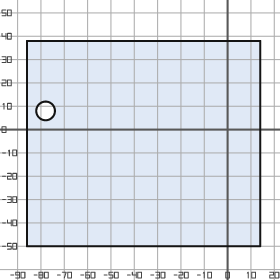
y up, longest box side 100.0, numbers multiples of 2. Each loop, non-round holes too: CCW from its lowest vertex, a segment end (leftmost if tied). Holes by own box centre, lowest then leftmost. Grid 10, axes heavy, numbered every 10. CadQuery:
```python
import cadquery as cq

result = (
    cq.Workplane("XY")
    .moveTo(-86.0, -50.0)
    .lineTo(14.0, -50.0)
    .lineTo(14.0, 38.0)
    .lineTo(-86.0, 38.0)
    .close()
    .moveTo(-78.0, 8.0)
    .circle(4.0)
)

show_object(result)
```